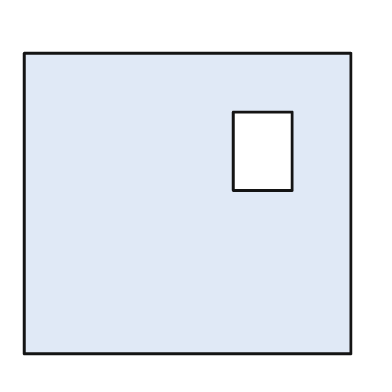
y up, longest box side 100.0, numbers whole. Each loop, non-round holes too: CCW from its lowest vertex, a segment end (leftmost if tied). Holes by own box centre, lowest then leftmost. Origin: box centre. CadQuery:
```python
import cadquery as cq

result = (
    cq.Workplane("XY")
    .moveTo(-50.0, -46.0)
    .lineTo(50.0, -46.0)
    .lineTo(50.0, 46.0)
    .lineTo(-50.0, 46.0)
    .close()
    .moveTo(14.0, 4.0)
    .lineTo(32.0, 4.0)
    .lineTo(32.0, 28.0)
    .lineTo(14.0, 28.0)
    .close()
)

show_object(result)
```